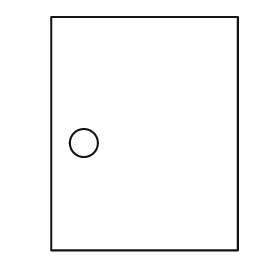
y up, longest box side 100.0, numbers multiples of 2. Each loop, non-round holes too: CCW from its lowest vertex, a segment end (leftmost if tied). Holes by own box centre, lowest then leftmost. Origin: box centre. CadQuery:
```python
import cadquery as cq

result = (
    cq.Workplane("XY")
    .moveTo(-40.0, -50.0)
    .lineTo(40.0, -50.0)
    .lineTo(40.0, 50.0)
    .lineTo(-40.0, 50.0)
    .close()
    .moveTo(-26.0, -4.0)
    .circle(6.0)
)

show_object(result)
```